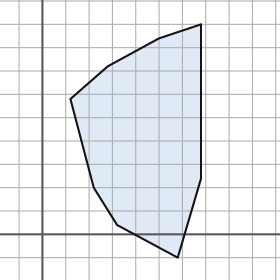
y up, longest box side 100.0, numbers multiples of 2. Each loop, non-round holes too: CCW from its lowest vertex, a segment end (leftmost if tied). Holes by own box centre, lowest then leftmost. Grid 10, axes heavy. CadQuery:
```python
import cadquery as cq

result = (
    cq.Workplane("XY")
    .moveTo(58.0, -10.0)
    .lineTo(68.0, 24.0)
    .lineTo(68.0, 90.0)
    .lineTo(50.0, 84.0)
    .lineTo(28.0, 72.0)
    .lineTo(12.0, 58.0)
    .lineTo(22.0, 20.0)
    .lineTo(32.0, 4.0)
    .close()
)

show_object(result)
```